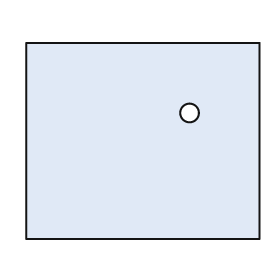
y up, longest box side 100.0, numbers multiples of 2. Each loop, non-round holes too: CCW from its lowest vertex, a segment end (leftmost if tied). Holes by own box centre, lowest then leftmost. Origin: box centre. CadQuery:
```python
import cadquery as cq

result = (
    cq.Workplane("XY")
    .moveTo(-50.0, -42.0)
    .lineTo(50.0, -42.0)
    .lineTo(50.0, 42.0)
    .lineTo(-50.0, 42.0)
    .close()
    .moveTo(20.0, 12.0)
    .circle(4.0)
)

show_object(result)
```